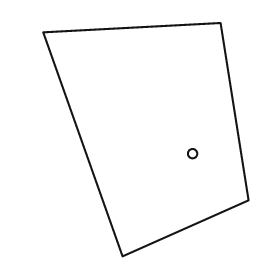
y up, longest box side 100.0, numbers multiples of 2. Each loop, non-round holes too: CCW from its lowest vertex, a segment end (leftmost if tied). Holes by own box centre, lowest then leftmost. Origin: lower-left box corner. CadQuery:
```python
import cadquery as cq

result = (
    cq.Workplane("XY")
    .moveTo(34.0, 0.0)
    .lineTo(88.0, 24.0)
    .lineTo(76.0, 100.0)
    .lineTo(0.0, 96.0)
    .close()
    .moveTo(64.0, 44.0)
    .circle(2.0)
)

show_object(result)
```